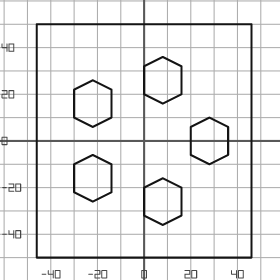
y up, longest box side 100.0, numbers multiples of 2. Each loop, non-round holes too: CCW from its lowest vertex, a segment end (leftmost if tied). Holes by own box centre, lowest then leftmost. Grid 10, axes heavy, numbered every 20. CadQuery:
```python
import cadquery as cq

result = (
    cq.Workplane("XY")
    .moveTo(-46.0, -50.0)
    .lineTo(46.0, -50.0)
    .lineTo(46.0, 50.0)
    .lineTo(-46.0, 50.0)
    .close()
    .moveTo(8.0, -36.0)
    .lineTo(16.0, -32.0)
    .lineTo(16.0, -20.0)
    .lineTo(8.0, -16.0)
    .lineTo(0.0, -20.0)
    .lineTo(0.0, -32.0)
    .close()
    .moveTo(-22.0, -26.0)
    .lineTo(-14.0, -22.0)
    .lineTo(-14.0, -10.0)
    .lineTo(-22.0, -6.0)
    .lineTo(-30.0, -10.0)
    .lineTo(-30.0, -22.0)
    .close()
    .moveTo(28.0, -10.0)
    .lineTo(36.0, -6.0)
    .lineTo(36.0, 6.0)
    .lineTo(28.0, 10.0)
    .lineTo(20.0, 6.0)
    .lineTo(20.0, -6.0)
    .close()
    .moveTo(-22.0, 6.0)
    .lineTo(-14.0, 10.0)
    .lineTo(-14.0, 22.0)
    .lineTo(-22.0, 26.0)
    .lineTo(-30.0, 22.0)
    .lineTo(-30.0, 10.0)
    .close()
    .moveTo(8.0, 16.0)
    .lineTo(16.0, 20.0)
    .lineTo(16.0, 32.0)
    .lineTo(8.0, 36.0)
    .lineTo(0.0, 32.0)
    .lineTo(0.0, 20.0)
    .close()
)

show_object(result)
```